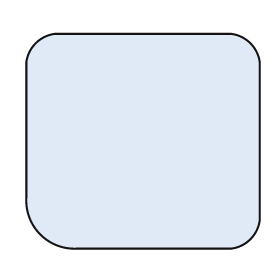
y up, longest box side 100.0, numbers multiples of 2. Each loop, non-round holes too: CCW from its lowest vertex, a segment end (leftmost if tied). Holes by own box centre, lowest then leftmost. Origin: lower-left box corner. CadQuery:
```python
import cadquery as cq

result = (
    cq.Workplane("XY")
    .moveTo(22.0, 0.0)
    .lineTo(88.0, 0.0)
    .threePointArc((96.0, 4.0), (100.0, 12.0))
    .lineTo(100.0, 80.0)
    .threePointArc((96.0, 88.0), (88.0, 92.0))
    .lineTo(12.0, 92.0)
    .threePointArc((4.0, 88.0), (0.0, 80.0))
    .lineTo(0.0, 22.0)
    .threePointArc((6.0, 6.0), (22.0, 0.0))
    .close()
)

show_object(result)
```